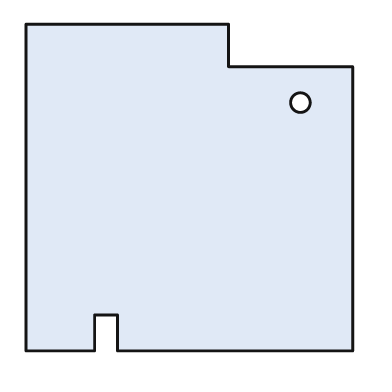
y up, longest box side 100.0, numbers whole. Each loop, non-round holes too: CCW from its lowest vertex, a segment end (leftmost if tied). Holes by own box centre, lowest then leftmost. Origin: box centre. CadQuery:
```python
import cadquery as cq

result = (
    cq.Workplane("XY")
    .moveTo(-50.0, -50.0)
    .lineTo(-29.0, -50.0)
    .lineTo(-29.0, -39.0)
    .lineTo(-22.0, -39.0)
    .lineTo(-22.0, -50.0)
    .lineTo(50.0, -50.0)
    .lineTo(50.0, 37.0)
    .lineTo(12.0, 37.0)
    .lineTo(12.0, 50.0)
    .lineTo(-50.0, 50.0)
    .close()
    .moveTo(34.0, 26.0)
    .circle(3.0)
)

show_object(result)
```